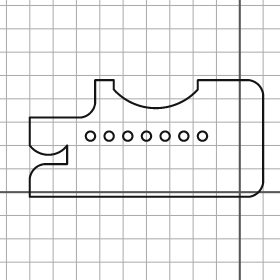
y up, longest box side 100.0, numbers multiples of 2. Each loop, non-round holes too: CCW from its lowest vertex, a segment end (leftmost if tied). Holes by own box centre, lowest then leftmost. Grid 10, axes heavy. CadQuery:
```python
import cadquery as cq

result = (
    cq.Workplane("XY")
    .moveTo(-90.0, -2.0)
    .lineTo(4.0, -2.0)
    .threePointArc((8.0, 0.0), (10.0, 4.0))
    .lineTo(10.0, 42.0)
    .threePointArc((8.0, 46.0), (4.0, 48.0))
    .lineTo(-18.0, 48.0)
    .lineTo(-18.0, 44.0)
    .threePointArc((-36.0, 36.0), (-54.0, 44.0))
    .lineTo(-54.0, 48.0)
    .lineTo(-62.0, 48.0)
    .lineTo(-62.0, 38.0)
    .threePointArc((-64.0, 34.0), (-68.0, 32.0))
    .lineTo(-90.0, 32.0)
    .lineTo(-90.0, 20.0)
    .threePointArc((-82.0, 16.0), (-74.0, 20.0))
    .lineTo(-74.0, 12.0)
    .lineTo(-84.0, 12.0)
    .threePointArc((-88.0, 10.0), (-90.0, 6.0))
    .close()
    .moveTo(-64.0, 24.0)
    .circle(2.0)
    .moveTo(-56.0, 24.0)
    .circle(2.0)
    .moveTo(-48.0, 24.0)
    .circle(2.0)
    .moveTo(-40.0, 24.0)
    .circle(2.0)
    .moveTo(-32.0, 24.0)
    .circle(2.0)
    .moveTo(-24.0, 24.0)
    .circle(2.0)
    .moveTo(-16.0, 24.0)
    .circle(2.0)
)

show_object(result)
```